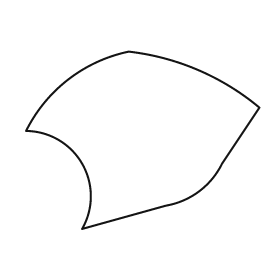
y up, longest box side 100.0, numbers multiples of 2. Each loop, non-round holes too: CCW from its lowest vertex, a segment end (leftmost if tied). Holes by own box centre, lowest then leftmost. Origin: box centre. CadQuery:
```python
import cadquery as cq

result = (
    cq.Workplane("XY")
    .moveTo(-26.0, -38.0)
    .lineTo(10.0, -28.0)
    .threePointArc((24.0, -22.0), (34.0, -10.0))
    .lineTo(50.0, 14.0)
    .threePointArc((24.0, 30.0), (-6.0, 38.0))
    .threePointArc((-32.0, 26.0), (-50.0, 4.0))
    .threePointArc((-26.0, -10.0), (-26.0, -38.0))
    .close()
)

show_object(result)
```